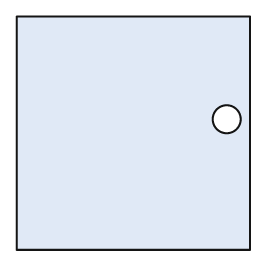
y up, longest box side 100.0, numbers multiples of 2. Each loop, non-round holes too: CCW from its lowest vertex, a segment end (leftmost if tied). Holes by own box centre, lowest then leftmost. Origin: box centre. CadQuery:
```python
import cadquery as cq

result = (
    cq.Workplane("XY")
    .moveTo(-50.0, -50.0)
    .lineTo(50.0, -50.0)
    .lineTo(50.0, 50.0)
    .lineTo(-50.0, 50.0)
    .close()
    .moveTo(40.0, 6.0)
    .circle(6.0)
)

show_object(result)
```